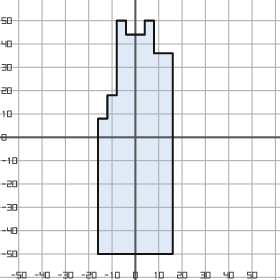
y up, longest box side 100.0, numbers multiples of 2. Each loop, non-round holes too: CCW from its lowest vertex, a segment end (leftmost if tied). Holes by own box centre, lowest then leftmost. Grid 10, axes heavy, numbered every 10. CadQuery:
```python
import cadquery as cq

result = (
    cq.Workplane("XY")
    .moveTo(-16.0, -50.0)
    .lineTo(16.0, -50.0)
    .lineTo(16.0, 36.0)
    .lineTo(8.0, 36.0)
    .lineTo(8.0, 50.0)
    .lineTo(4.0, 50.0)
    .lineTo(4.0, 44.0)
    .lineTo(-4.0, 44.0)
    .lineTo(-4.0, 50.0)
    .lineTo(-8.0, 50.0)
    .lineTo(-8.0, 18.0)
    .lineTo(-12.0, 18.0)
    .lineTo(-12.0, 8.0)
    .lineTo(-16.0, 8.0)
    .close()
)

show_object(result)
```